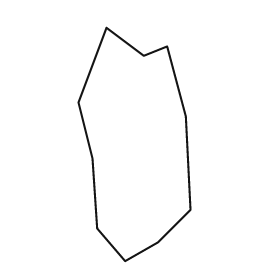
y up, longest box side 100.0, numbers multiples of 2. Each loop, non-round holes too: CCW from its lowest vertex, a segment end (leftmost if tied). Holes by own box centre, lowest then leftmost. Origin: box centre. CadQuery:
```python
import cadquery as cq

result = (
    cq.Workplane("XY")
    .moveTo(-4.0, -50.0)
    .lineTo(10.0, -42.0)
    .lineTo(24.0, -28.0)
    .lineTo(22.0, 12.0)
    .lineTo(14.0, 42.0)
    .lineTo(4.0, 38.0)
    .lineTo(-12.0, 50.0)
    .lineTo(-24.0, 18.0)
    .lineTo(-18.0, -6.0)
    .lineTo(-16.0, -36.0)
    .close()
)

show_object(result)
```